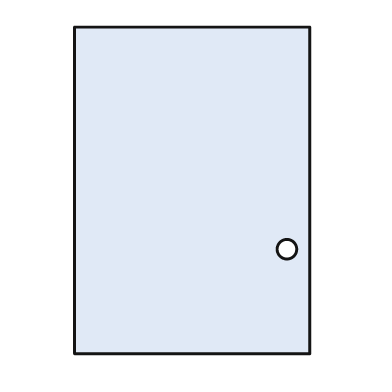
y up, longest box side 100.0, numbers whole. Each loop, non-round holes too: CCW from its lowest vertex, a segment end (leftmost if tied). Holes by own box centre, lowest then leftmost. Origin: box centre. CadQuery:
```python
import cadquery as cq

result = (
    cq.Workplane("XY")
    .moveTo(-36.0, -50.0)
    .lineTo(36.0, -50.0)
    .lineTo(36.0, 50.0)
    .lineTo(-36.0, 50.0)
    .close()
    .moveTo(29.0, -18.0)
    .circle(3.0)
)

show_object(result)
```